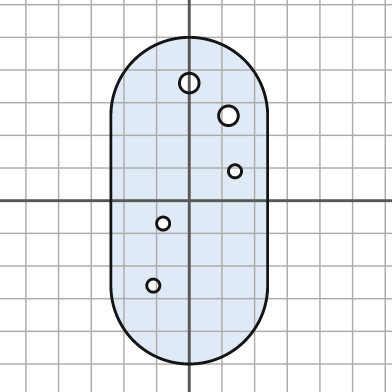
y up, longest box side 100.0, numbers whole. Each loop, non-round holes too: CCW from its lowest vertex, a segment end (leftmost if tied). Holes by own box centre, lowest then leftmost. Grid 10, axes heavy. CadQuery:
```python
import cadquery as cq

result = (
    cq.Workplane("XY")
    .moveTo(-24.0, -26.0)
    .threePointArc((0.0, -50.0), (24.0, -26.0))
    .lineTo(24.0, 26.0)
    .threePointArc((0.0, 50.0), (-24.0, 26.0))
    .close()
    .moveTo(-11.0, -26.0)
    .circle(2.0)
    .moveTo(-8.0, -7.0)
    .circle(2.0)
    .moveTo(14.0, 9.0)
    .circle(2.0)
    .moveTo(12.0, 26.0)
    .circle(3.0)
    .moveTo(0.0, 36.0)
    .circle(3.0)
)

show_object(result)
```